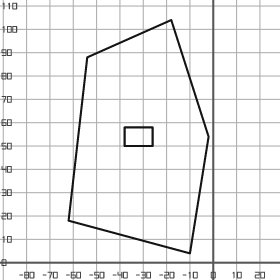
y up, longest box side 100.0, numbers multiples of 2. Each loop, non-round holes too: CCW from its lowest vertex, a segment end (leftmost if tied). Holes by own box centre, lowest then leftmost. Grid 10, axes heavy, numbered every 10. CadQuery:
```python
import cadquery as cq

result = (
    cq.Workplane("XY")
    .moveTo(-10.0, 4.0)
    .lineTo(-2.0, 54.0)
    .lineTo(-18.0, 104.0)
    .lineTo(-54.0, 88.0)
    .lineTo(-62.0, 18.0)
    .close()
    .moveTo(-38.0, 50.0)
    .lineTo(-26.0, 50.0)
    .lineTo(-26.0, 58.0)
    .lineTo(-38.0, 58.0)
    .close()
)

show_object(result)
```